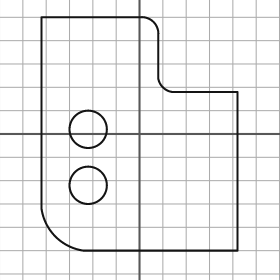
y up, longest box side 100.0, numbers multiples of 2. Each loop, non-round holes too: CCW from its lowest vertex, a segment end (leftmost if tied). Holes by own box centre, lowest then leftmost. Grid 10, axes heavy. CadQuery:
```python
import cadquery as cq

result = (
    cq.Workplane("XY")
    .moveTo(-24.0, -50.0)
    .lineTo(42.0, -50.0)
    .lineTo(42.0, 18.0)
    .lineTo(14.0, 18.0)
    .threePointArc((10.0, 20.0), (8.0, 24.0))
    .lineTo(8.0, 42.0)
    .threePointArc((6.0, 48.0), (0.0, 50.0))
    .lineTo(-42.0, 50.0)
    .lineTo(-42.0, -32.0)
    .threePointArc((-36.0, -44.0), (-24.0, -50.0))
    .close()
    .moveTo(-22.0, -22.0)
    .circle(8.0)
    .moveTo(-22.0, 2.0)
    .circle(8.0)
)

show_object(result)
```